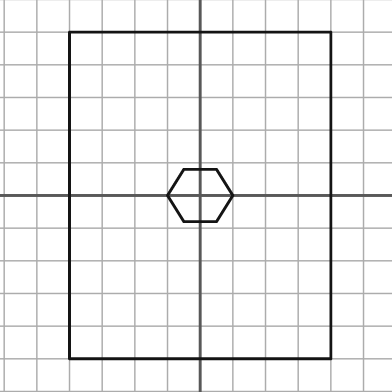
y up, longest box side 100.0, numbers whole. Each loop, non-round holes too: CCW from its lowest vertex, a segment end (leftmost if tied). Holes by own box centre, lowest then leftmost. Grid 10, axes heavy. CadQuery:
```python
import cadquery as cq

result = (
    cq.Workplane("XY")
    .moveTo(-40.0, -50.0)
    .lineTo(40.0, -50.0)
    .lineTo(40.0, 50.0)
    .lineTo(-40.0, 50.0)
    .close()
    .moveTo(-5.0, -8.0)
    .lineTo(5.0, -8.0)
    .lineTo(10.0, 0.0)
    .lineTo(5.0, 8.0)
    .lineTo(-5.0, 8.0)
    .lineTo(-10.0, 0.0)
    .close()
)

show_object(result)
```